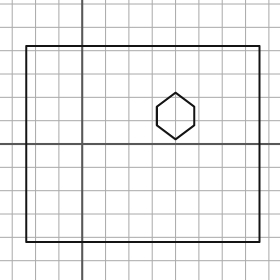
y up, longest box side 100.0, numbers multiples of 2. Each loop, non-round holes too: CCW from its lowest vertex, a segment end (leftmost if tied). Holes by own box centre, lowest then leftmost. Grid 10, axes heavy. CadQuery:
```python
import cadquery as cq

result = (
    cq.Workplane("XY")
    .moveTo(-24.0, -42.0)
    .lineTo(76.0, -42.0)
    .lineTo(76.0, 42.0)
    .lineTo(-24.0, 42.0)
    .close()
    .moveTo(40.0, 2.0)
    .lineTo(48.0, 8.0)
    .lineTo(48.0, 16.0)
    .lineTo(40.0, 22.0)
    .lineTo(32.0, 16.0)
    .lineTo(32.0, 8.0)
    .close()
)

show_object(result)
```